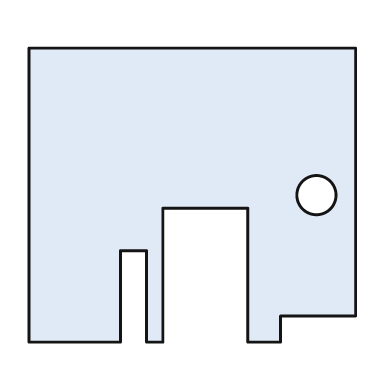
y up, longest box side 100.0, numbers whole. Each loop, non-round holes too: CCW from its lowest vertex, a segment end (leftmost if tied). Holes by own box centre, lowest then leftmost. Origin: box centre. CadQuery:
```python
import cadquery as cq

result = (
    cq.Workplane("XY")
    .moveTo(-50.0, -45.0)
    .lineTo(-22.0, -45.0)
    .lineTo(-22.0, -17.0)
    .lineTo(-14.0, -17.0)
    .lineTo(-14.0, -45.0)
    .lineTo(-9.0, -45.0)
    .lineTo(-9.0, -4.0)
    .lineTo(17.0, -4.0)
    .lineTo(17.0, -45.0)
    .lineTo(27.0, -45.0)
    .lineTo(27.0, -37.0)
    .lineTo(50.0, -37.0)
    .lineTo(50.0, 45.0)
    .lineTo(-50.0, 45.0)
    .close()
    .moveTo(38.0, 0.0)
    .circle(6.0)
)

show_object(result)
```